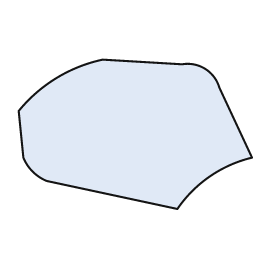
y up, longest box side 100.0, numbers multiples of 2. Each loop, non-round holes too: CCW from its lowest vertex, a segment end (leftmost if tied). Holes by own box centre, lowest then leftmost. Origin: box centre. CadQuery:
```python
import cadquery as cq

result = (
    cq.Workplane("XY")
    .moveTo(18.0, -32.0)
    .threePointArc((32.0, -18.0), (50.0, -10.0))
    .lineTo(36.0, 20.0)
    .threePointArc((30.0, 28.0), (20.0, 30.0))
    .lineTo(-14.0, 32.0)
    .threePointArc((-34.0, 24.0), (-50.0, 10.0))
    .lineTo(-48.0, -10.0)
    .threePointArc((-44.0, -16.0), (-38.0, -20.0))
    .close()
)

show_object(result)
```